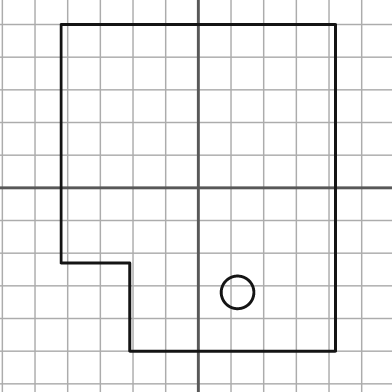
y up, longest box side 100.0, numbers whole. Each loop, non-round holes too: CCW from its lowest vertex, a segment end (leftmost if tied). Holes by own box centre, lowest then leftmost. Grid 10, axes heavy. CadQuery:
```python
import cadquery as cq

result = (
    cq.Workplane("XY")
    .moveTo(-21.0, -50.0)
    .lineTo(42.0, -50.0)
    .lineTo(42.0, 50.0)
    .lineTo(-42.0, 50.0)
    .lineTo(-42.0, -23.0)
    .lineTo(-21.0, -23.0)
    .close()
    .moveTo(12.0, -32.0)
    .circle(5.0)
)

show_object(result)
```